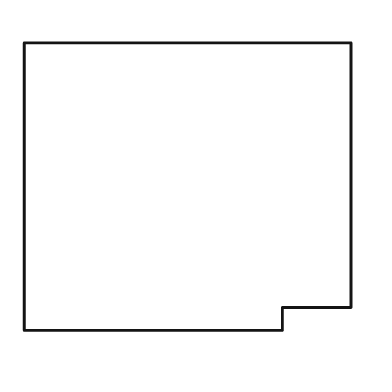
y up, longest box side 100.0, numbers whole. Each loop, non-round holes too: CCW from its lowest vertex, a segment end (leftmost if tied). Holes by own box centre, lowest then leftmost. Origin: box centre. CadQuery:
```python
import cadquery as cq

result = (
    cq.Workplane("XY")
    .moveTo(-50.0, -44.0)
    .lineTo(29.0, -44.0)
    .lineTo(29.0, -37.0)
    .lineTo(50.0, -37.0)
    .lineTo(50.0, 44.0)
    .lineTo(-50.0, 44.0)
    .close()
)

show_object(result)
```